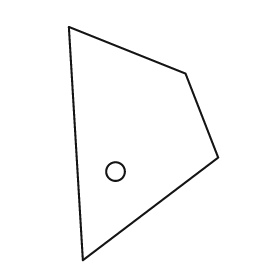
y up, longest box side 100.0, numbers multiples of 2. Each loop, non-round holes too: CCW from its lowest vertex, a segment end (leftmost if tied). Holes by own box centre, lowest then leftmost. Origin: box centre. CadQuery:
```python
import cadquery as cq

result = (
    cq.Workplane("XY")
    .moveTo(-26.0, -50.0)
    .lineTo(32.0, -6.0)
    .lineTo(18.0, 30.0)
    .lineTo(-32.0, 50.0)
    .close()
    .moveTo(-12.0, -12.0)
    .circle(4.0)
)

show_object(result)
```